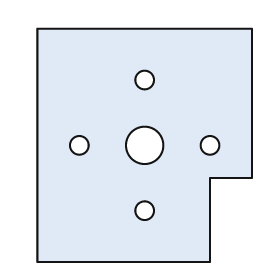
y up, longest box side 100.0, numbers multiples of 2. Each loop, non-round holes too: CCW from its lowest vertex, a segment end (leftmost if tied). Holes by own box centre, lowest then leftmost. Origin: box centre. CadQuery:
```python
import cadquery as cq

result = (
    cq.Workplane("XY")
    .moveTo(-46.0, -50.0)
    .lineTo(28.0, -50.0)
    .lineTo(28.0, -14.0)
    .lineTo(46.0, -14.0)
    .lineTo(46.0, 50.0)
    .lineTo(-46.0, 50.0)
    .close()
    .moveTo(0.0, -28.0)
    .circle(4.0)
    .moveTo(-28.0, 0.0)
    .circle(4.0)
    .moveTo(0.0, 0.0)
    .circle(8.0)
    .moveTo(28.0, 0.0)
    .circle(4.0)
    .moveTo(0.0, 28.0)
    .circle(4.0)
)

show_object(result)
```